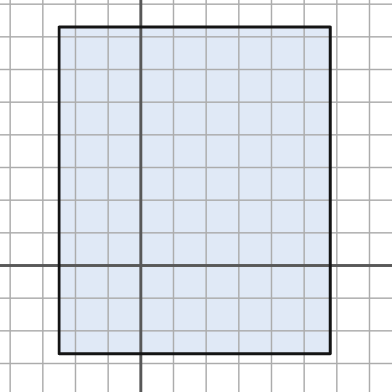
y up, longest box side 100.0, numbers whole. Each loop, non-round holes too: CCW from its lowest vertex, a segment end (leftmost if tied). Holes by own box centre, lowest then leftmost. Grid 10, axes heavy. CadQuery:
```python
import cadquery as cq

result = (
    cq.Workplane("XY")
    .moveTo(-25.0, -27.0)
    .lineTo(58.0, -27.0)
    .lineTo(58.0, 73.0)
    .lineTo(-25.0, 73.0)
    .close()
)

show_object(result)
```